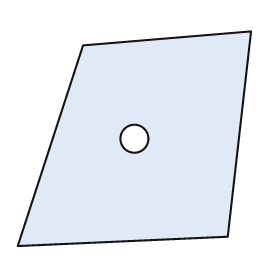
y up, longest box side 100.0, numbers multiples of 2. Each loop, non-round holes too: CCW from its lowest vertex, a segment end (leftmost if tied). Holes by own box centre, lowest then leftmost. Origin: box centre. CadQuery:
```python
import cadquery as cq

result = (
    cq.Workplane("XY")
    .moveTo(-50.0, -46.0)
    .lineTo(40.0, -42.0)
    .lineTo(50.0, 46.0)
    .lineTo(-22.0, 40.0)
    .close()
    .moveTo(0.0, 0.0)
    .circle(6.0)
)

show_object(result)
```